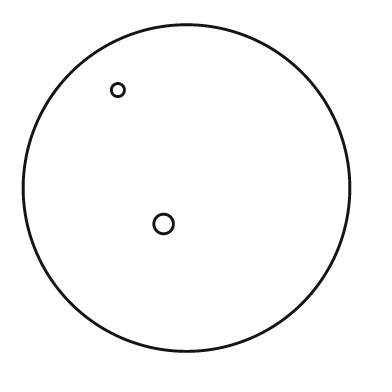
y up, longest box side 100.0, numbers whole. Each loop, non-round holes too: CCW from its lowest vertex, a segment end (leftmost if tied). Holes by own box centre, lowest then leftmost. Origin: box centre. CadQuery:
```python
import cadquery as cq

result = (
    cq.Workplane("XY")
    .moveTo(0.0, 0.0)
    .circle(50.0)
    .moveTo(-7.0, -11.0)
    .circle(3.0)
    .moveTo(-21.0, 30.0)
    .circle(2.0)
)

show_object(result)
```